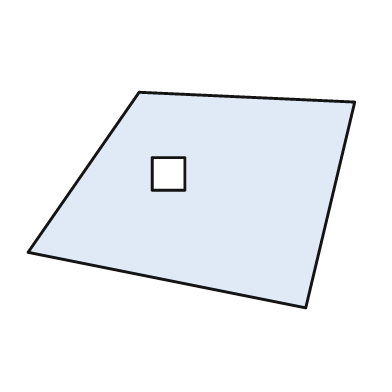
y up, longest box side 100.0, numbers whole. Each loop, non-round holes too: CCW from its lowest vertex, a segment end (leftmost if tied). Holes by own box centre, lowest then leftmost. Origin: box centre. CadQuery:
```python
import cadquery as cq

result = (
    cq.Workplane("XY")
    .moveTo(35.0, -33.0)
    .lineTo(50.0, 30.0)
    .lineTo(-16.0, 33.0)
    .lineTo(-50.0, -16.0)
    .close()
    .moveTo(-12.0, 3.0)
    .lineTo(-2.0, 3.0)
    .lineTo(-2.0, 13.0)
    .lineTo(-12.0, 13.0)
    .close()
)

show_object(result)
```